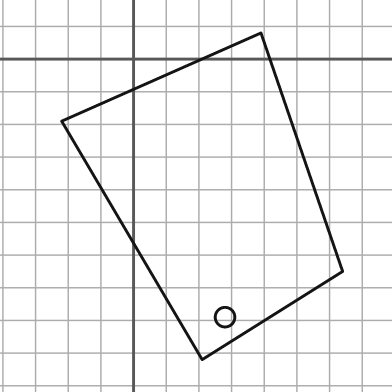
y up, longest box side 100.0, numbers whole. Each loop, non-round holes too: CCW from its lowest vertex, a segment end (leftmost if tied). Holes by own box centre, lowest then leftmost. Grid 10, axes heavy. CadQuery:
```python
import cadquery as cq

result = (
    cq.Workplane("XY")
    .moveTo(21.0, -92.0)
    .lineTo(64.0, -65.0)
    .lineTo(39.0, 8.0)
    .lineTo(-22.0, -19.0)
    .close()
    .moveTo(28.0, -79.0)
    .circle(3.0)
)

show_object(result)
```